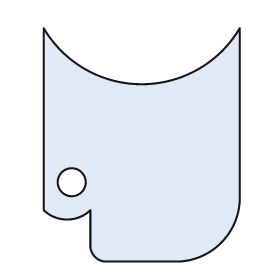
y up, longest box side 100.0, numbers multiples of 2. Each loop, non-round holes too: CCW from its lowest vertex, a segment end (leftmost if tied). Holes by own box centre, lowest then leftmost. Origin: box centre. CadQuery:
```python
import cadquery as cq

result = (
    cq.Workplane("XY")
    .moveTo(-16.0, -50.0)
    .lineTo(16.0, -50.0)
    .threePointArc((34.0, -42.0), (42.0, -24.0))
    .lineTo(42.0, 50.0)
    .threePointArc((0.0, 26.0), (-42.0, 50.0))
    .lineTo(-42.0, -28.0)
    .threePointArc((-32.0, -32.0), (-22.0, -28.0))
    .lineTo(-22.0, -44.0)
    .threePointArc((-20.0, -48.0), (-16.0, -50.0))
    .close()
    .moveTo(-30.0, -16.0)
    .circle(6.0)
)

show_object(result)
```